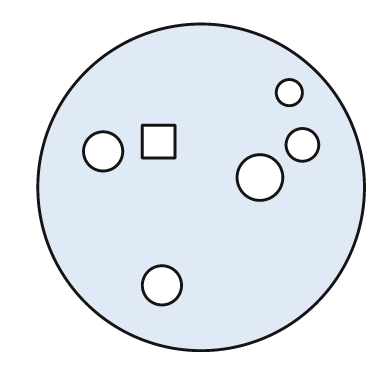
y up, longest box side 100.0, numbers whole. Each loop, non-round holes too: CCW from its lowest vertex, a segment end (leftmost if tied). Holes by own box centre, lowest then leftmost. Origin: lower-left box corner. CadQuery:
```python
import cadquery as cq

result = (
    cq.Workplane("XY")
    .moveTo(50.0, 50.0)
    .circle(50.0)
    .moveTo(38.0, 20.0)
    .circle(6.0)
    .moveTo(68.0, 53.0)
    .circle(7.0)
    .moveTo(20.0, 61.0)
    .circle(6.0)
    .moveTo(81.0, 63.0)
    .circle(5.0)
    .moveTo(32.0, 59.0)
    .lineTo(42.0, 59.0)
    .lineTo(42.0, 69.0)
    .lineTo(32.0, 69.0)
    .close()
    .moveTo(77.0, 79.0)
    .circle(4.0)
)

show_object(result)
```